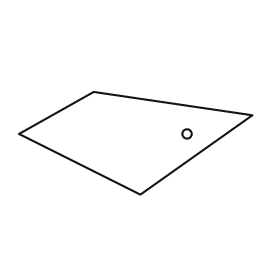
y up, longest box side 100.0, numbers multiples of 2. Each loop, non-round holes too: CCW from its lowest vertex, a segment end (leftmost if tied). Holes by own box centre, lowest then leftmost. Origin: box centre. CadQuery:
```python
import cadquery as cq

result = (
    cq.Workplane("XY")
    .moveTo(2.0, -22.0)
    .lineTo(50.0, 12.0)
    .lineTo(-18.0, 22.0)
    .lineTo(-50.0, 4.0)
    .close()
    .moveTo(22.0, 4.0)
    .circle(2.0)
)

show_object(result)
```